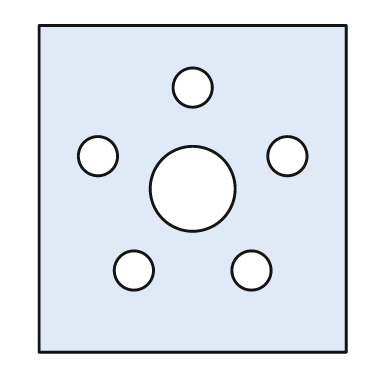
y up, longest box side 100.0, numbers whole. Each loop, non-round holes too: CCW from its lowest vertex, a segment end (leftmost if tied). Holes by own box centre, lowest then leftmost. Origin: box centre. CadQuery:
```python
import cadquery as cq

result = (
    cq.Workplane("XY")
    .moveTo(-47.0, -50.0)
    .lineTo(47.0, -50.0)
    .lineTo(47.0, 50.0)
    .lineTo(-47.0, 50.0)
    .close()
    .moveTo(-18.0, -25.0)
    .circle(6.0)
    .moveTo(18.0, -25.0)
    .circle(6.0)
    .moveTo(0.0, 0.0)
    .circle(13.0)
    .moveTo(-29.0, 10.0)
    .circle(6.0)
    .moveTo(29.0, 10.0)
    .circle(6.0)
    .moveTo(0.0, 31.0)
    .circle(6.0)
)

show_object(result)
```